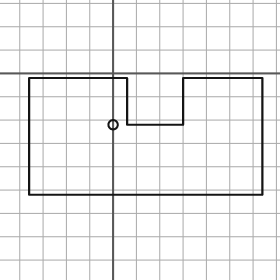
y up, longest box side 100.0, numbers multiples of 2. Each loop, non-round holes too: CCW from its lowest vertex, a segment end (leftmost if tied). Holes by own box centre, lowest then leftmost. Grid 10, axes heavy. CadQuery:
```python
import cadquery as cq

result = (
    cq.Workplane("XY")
    .moveTo(-36.0, -52.0)
    .lineTo(64.0, -52.0)
    .lineTo(64.0, -2.0)
    .lineTo(30.0, -2.0)
    .lineTo(30.0, -22.0)
    .lineTo(6.0, -22.0)
    .lineTo(6.0, -2.0)
    .lineTo(-36.0, -2.0)
    .close()
    .moveTo(0.0, -22.0)
    .circle(2.0)
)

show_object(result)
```